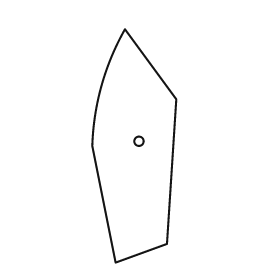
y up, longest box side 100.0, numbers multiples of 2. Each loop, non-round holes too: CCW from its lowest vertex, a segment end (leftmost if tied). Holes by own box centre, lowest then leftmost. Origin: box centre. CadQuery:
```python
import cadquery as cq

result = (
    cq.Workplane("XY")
    .moveTo(-8.0, -50.0)
    .lineTo(14.0, -42.0)
    .lineTo(18.0, 20.0)
    .lineTo(-4.0, 50.0)
    .threePointArc((-14.0, 26.0), (-18.0, 0.0))
    .close()
    .moveTo(2.0, 2.0)
    .circle(2.0)
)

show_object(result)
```